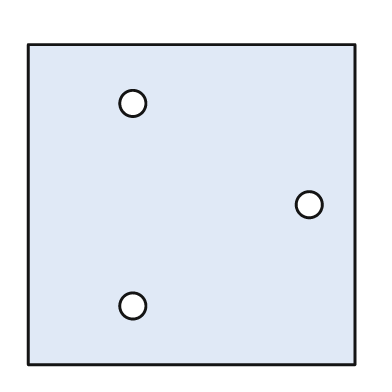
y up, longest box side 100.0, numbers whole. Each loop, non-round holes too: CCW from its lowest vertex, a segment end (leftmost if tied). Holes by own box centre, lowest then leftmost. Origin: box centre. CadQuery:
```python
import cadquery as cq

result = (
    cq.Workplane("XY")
    .moveTo(-50.0, -49.0)
    .lineTo(50.0, -49.0)
    .lineTo(50.0, 49.0)
    .lineTo(-50.0, 49.0)
    .close()
    .moveTo(-18.0, -31.0)
    .circle(4.0)
    .moveTo(36.0, 0.0)
    .circle(4.0)
    .moveTo(-18.0, 31.0)
    .circle(4.0)
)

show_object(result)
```